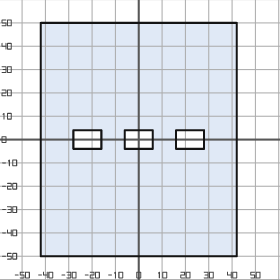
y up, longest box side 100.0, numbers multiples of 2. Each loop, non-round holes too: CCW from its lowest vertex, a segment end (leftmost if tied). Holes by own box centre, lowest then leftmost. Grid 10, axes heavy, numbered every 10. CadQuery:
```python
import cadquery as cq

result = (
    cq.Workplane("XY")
    .moveTo(-42.0, -50.0)
    .lineTo(42.0, -50.0)
    .lineTo(42.0, 50.0)
    .lineTo(-42.0, 50.0)
    .close()
    .moveTo(-28.0, -4.0)
    .lineTo(-16.0, -4.0)
    .lineTo(-16.0, 4.0)
    .lineTo(-28.0, 4.0)
    .close()
    .moveTo(-6.0, -4.0)
    .lineTo(6.0, -4.0)
    .lineTo(6.0, 4.0)
    .lineTo(-6.0, 4.0)
    .close()
    .moveTo(16.0, -4.0)
    .lineTo(28.0, -4.0)
    .lineTo(28.0, 4.0)
    .lineTo(16.0, 4.0)
    .close()
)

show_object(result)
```